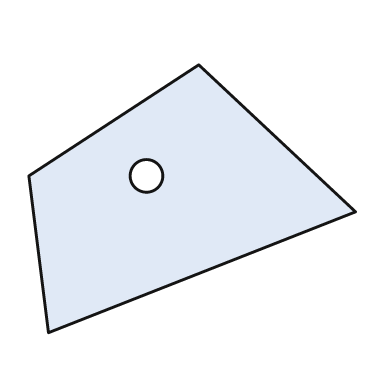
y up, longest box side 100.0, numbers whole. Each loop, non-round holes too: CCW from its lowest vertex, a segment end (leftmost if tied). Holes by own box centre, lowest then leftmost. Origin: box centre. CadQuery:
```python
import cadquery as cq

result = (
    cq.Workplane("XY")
    .moveTo(-44.0, -41.0)
    .lineTo(50.0, -4.0)
    .lineTo(2.0, 41.0)
    .lineTo(-50.0, 7.0)
    .close()
    .moveTo(-14.0, 7.0)
    .circle(5.0)
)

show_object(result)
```